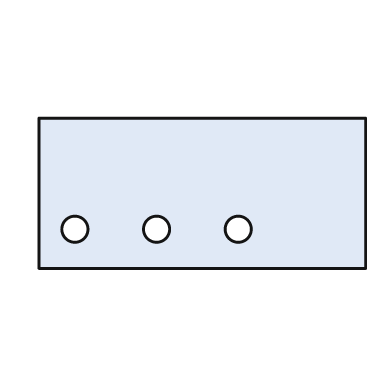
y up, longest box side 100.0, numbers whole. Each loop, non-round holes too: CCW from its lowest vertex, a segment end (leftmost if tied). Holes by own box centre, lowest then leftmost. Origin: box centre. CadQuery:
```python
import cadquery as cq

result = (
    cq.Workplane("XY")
    .moveTo(-50.0, -23.0)
    .lineTo(50.0, -23.0)
    .lineTo(50.0, 23.0)
    .lineTo(-50.0, 23.0)
    .close()
    .moveTo(-39.0, -11.0)
    .circle(4.0)
    .moveTo(-14.0, -11.0)
    .circle(4.0)
    .moveTo(11.0, -11.0)
    .circle(4.0)
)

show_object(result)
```